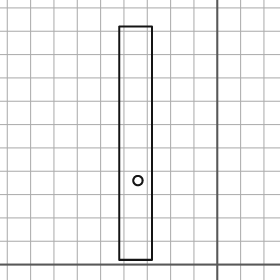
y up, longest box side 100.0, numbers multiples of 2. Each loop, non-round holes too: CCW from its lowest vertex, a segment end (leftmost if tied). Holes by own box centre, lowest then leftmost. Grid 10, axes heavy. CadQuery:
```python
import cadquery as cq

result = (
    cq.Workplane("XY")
    .moveTo(-42.0, 2.0)
    .lineTo(-28.0, 2.0)
    .lineTo(-28.0, 102.0)
    .lineTo(-42.0, 102.0)
    .close()
    .moveTo(-34.0, 36.0)
    .circle(2.0)
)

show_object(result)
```